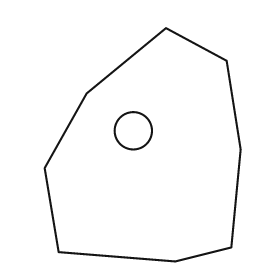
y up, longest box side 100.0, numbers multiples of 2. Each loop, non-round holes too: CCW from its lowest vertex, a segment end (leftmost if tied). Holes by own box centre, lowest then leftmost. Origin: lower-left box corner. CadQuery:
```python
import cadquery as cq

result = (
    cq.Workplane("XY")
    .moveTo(56.0, 0.0)
    .lineTo(80.0, 6.0)
    .lineTo(84.0, 48.0)
    .lineTo(78.0, 86.0)
    .lineTo(52.0, 100.0)
    .lineTo(18.0, 72.0)
    .lineTo(0.0, 40.0)
    .lineTo(6.0, 4.0)
    .close()
    .moveTo(38.0, 56.0)
    .circle(8.0)
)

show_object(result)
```